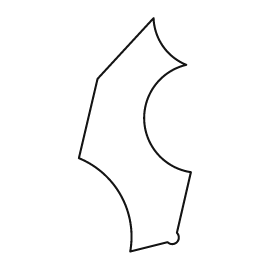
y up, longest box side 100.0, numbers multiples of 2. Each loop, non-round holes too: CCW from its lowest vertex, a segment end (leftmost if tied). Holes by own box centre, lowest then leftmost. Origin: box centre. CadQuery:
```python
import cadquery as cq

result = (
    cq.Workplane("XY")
    .moveTo(-2.0, -50.0)
    .lineTo(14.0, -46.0)
    .threePointArc((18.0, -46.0), (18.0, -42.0))
    .lineTo(24.0, -16.0)
    .threePointArc((4.0, 6.0), (22.0, 30.0))
    .threePointArc((12.0, 38.0), (8.0, 50.0))
    .lineTo(-16.0, 24.0)
    .lineTo(-24.0, -10.0)
    .threePointArc((-6.0, -26.0), (-2.0, -50.0))
    .close()
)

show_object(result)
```